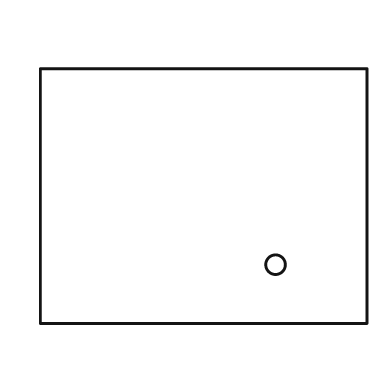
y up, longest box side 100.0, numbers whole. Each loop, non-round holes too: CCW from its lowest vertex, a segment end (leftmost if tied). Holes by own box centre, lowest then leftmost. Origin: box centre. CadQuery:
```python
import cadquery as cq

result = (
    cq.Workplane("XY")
    .moveTo(-50.0, -39.0)
    .lineTo(50.0, -39.0)
    .lineTo(50.0, 39.0)
    .lineTo(-50.0, 39.0)
    .close()
    .moveTo(22.0, -21.0)
    .circle(3.0)
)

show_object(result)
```